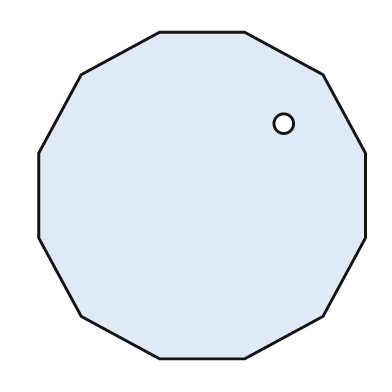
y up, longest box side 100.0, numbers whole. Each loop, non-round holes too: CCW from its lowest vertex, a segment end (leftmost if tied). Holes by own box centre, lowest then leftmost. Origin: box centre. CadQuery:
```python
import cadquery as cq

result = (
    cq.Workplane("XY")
    .moveTo(-13.0, -50.0)
    .lineTo(13.0, -50.0)
    .lineTo(37.0, -37.0)
    .lineTo(50.0, -13.0)
    .lineTo(50.0, 13.0)
    .lineTo(37.0, 37.0)
    .lineTo(13.0, 50.0)
    .lineTo(-13.0, 50.0)
    .lineTo(-37.0, 37.0)
    .lineTo(-50.0, 13.0)
    .lineTo(-50.0, -13.0)
    .lineTo(-37.0, -37.0)
    .close()
    .moveTo(25.0, 22.0)
    .circle(3.0)
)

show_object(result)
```